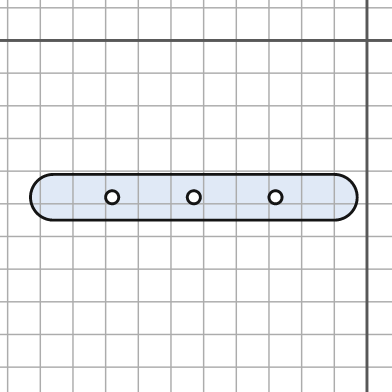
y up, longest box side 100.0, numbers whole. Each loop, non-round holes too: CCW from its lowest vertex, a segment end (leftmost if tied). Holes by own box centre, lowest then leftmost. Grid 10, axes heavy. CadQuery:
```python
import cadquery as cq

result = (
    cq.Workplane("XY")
    .moveTo(-96.0, -55.0)
    .lineTo(-10.0, -55.0)
    .threePointArc((-3.0, -48.0), (-10.0, -41.0))
    .lineTo(-96.0, -41.0)
    .threePointArc((-103.0, -48.0), (-96.0, -55.0))
    .close()
    .moveTo(-78.0, -48.0)
    .circle(2.0)
    .moveTo(-53.0, -48.0)
    .circle(2.0)
    .moveTo(-28.0, -48.0)
    .circle(2.0)
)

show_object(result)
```